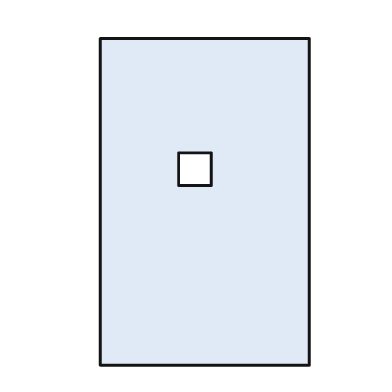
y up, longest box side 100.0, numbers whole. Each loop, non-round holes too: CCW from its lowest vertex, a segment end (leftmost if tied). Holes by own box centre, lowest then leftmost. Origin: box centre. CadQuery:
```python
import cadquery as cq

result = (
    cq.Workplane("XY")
    .moveTo(-32.0, -50.0)
    .lineTo(32.0, -50.0)
    .lineTo(32.0, 50.0)
    .lineTo(-32.0, 50.0)
    .close()
    .moveTo(-8.0, 5.0)
    .lineTo(2.0, 5.0)
    .lineTo(2.0, 15.0)
    .lineTo(-8.0, 15.0)
    .close()
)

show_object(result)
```